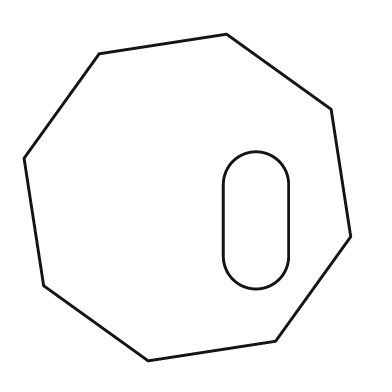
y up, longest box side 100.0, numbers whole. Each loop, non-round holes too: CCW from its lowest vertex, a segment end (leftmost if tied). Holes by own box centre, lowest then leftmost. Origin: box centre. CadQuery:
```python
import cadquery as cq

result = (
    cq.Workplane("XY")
    .moveTo(-12.0, -50.0)
    .lineTo(27.0, -44.0)
    .lineTo(50.0, -12.0)
    .lineTo(44.0, 27.0)
    .lineTo(12.0, 50.0)
    .lineTo(-27.0, 44.0)
    .lineTo(-50.0, 12.0)
    .lineTo(-44.0, -27.0)
    .close()
    .moveTo(11.0, -18.0)
    .threePointArc((21.0, -28.0), (31.0, -18.0))
    .lineTo(31.0, 4.0)
    .threePointArc((21.0, 14.0), (11.0, 4.0))
    .close()
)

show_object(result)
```